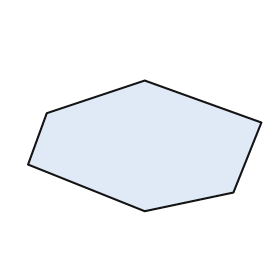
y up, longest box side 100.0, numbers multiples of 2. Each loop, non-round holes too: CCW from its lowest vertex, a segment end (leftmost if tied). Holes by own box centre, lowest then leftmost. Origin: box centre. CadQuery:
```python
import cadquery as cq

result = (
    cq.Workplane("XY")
    .moveTo(0.0, -28.0)
    .lineTo(38.0, -20.0)
    .lineTo(50.0, 10.0)
    .lineTo(0.0, 28.0)
    .lineTo(-42.0, 14.0)
    .lineTo(-50.0, -8.0)
    .close()
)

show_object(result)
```